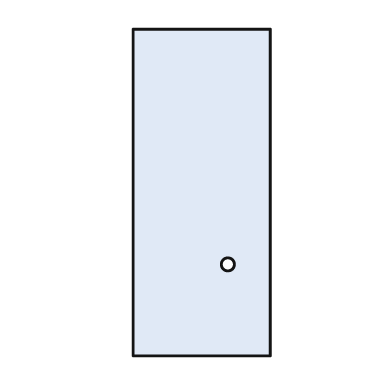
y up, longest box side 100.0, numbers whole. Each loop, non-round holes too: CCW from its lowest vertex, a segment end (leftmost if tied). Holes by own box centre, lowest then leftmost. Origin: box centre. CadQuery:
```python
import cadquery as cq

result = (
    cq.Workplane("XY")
    .moveTo(-21.0, -50.0)
    .lineTo(21.0, -50.0)
    .lineTo(21.0, 50.0)
    .lineTo(-21.0, 50.0)
    .close()
    .moveTo(8.0, -22.0)
    .circle(2.0)
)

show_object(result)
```